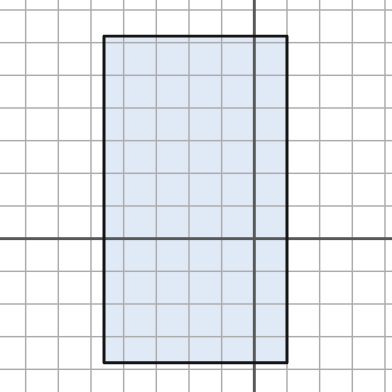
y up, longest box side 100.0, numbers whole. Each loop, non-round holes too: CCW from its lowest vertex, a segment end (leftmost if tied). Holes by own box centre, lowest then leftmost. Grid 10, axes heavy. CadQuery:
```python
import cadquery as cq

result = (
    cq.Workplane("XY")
    .moveTo(-46.0, -38.0)
    .lineTo(10.0, -38.0)
    .lineTo(10.0, 62.0)
    .lineTo(-46.0, 62.0)
    .close()
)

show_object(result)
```